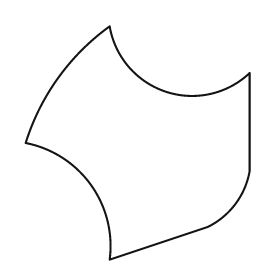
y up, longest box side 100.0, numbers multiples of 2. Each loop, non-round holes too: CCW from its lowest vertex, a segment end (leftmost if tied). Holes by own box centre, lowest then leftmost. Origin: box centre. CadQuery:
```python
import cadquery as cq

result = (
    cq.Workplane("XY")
    .moveTo(-12.0, -50.0)
    .lineTo(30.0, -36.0)
    .threePointArc((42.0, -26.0), (48.0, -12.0))
    .lineTo(48.0, 30.0)
    .threePointArc((12.0, 22.0), (-12.0, 50.0))
    .threePointArc((-34.0, 28.0), (-48.0, 0.0))
    .threePointArc((-20.0, -18.0), (-12.0, -50.0))
    .close()
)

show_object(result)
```